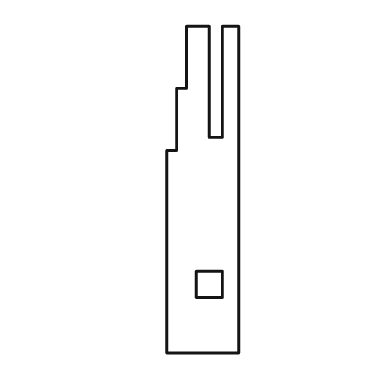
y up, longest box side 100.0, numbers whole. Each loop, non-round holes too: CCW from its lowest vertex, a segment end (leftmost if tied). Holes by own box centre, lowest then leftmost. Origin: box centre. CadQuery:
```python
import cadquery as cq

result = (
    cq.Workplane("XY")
    .moveTo(-11.0, -50.0)
    .lineTo(11.0, -50.0)
    .lineTo(11.0, 50.0)
    .lineTo(6.0, 50.0)
    .lineTo(6.0, 16.0)
    .lineTo(2.0, 16.0)
    .lineTo(2.0, 50.0)
    .lineTo(-5.0, 50.0)
    .lineTo(-5.0, 31.0)
    .lineTo(-8.0, 31.0)
    .lineTo(-8.0, 12.0)
    .lineTo(-11.0, 12.0)
    .close()
    .moveTo(-2.0, -33.0)
    .lineTo(6.0, -33.0)
    .lineTo(6.0, -25.0)
    .lineTo(-2.0, -25.0)
    .close()
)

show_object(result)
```